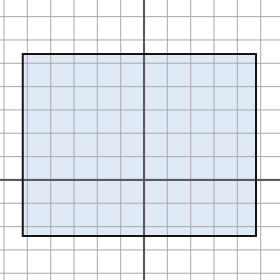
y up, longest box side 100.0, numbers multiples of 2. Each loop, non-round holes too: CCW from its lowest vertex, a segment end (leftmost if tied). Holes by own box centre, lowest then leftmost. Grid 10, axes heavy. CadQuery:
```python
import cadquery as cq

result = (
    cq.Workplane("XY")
    .moveTo(-52.0, -24.0)
    .lineTo(48.0, -24.0)
    .lineTo(48.0, 54.0)
    .lineTo(-52.0, 54.0)
    .close()
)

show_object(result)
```